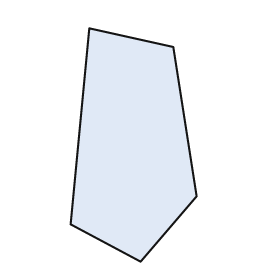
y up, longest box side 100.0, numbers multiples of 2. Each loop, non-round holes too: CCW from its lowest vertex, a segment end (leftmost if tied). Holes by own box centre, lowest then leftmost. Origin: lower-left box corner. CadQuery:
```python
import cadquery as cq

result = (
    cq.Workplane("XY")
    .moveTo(30.0, 0.0)
    .lineTo(54.0, 28.0)
    .lineTo(44.0, 92.0)
    .lineTo(8.0, 100.0)
    .lineTo(0.0, 16.0)
    .close()
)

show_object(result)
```